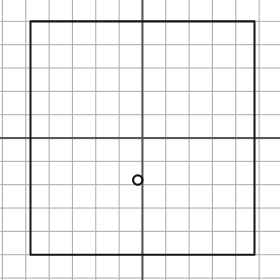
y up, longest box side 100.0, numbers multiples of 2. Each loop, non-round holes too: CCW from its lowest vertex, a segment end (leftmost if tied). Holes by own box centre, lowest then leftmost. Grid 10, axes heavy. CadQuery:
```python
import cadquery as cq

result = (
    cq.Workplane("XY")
    .moveTo(-48.0, -50.0)
    .lineTo(48.0, -50.0)
    .lineTo(48.0, 50.0)
    .lineTo(-48.0, 50.0)
    .close()
    .moveTo(-2.0, -18.0)
    .circle(2.0)
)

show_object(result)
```